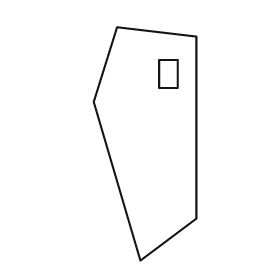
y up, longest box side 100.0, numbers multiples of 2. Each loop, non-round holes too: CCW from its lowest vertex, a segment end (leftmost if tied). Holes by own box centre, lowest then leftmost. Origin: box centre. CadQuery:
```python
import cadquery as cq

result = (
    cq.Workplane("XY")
    .moveTo(-2.0, -50.0)
    .lineTo(22.0, -32.0)
    .lineTo(22.0, 46.0)
    .lineTo(-12.0, 50.0)
    .lineTo(-22.0, 18.0)
    .close()
    .moveTo(6.0, 24.0)
    .lineTo(14.0, 24.0)
    .lineTo(14.0, 36.0)
    .lineTo(6.0, 36.0)
    .close()
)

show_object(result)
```